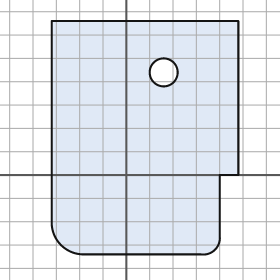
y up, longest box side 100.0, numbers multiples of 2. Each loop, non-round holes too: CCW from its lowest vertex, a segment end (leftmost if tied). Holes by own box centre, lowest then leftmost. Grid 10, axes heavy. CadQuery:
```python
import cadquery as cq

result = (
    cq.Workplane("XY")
    .moveTo(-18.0, -34.0)
    .lineTo(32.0, -34.0)
    .threePointArc((38.0, -32.0), (40.0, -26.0))
    .lineTo(40.0, 0.0)
    .lineTo(48.0, 0.0)
    .lineTo(48.0, 66.0)
    .lineTo(-32.0, 66.0)
    .lineTo(-32.0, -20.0)
    .threePointArc((-28.0, -30.0), (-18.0, -34.0))
    .close()
    .moveTo(16.0, 44.0)
    .circle(6.0)
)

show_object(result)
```